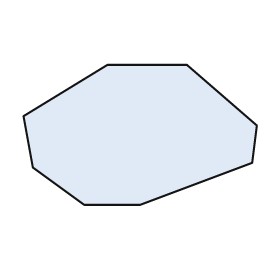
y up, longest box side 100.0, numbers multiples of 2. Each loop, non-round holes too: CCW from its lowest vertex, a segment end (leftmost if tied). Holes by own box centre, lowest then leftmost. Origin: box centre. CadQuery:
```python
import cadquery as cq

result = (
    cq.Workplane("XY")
    .moveTo(-24.0, -30.0)
    .lineTo(0.0, -30.0)
    .lineTo(48.0, -12.0)
    .lineTo(50.0, 4.0)
    .lineTo(20.0, 30.0)
    .lineTo(-14.0, 30.0)
    .lineTo(-50.0, 8.0)
    .lineTo(-46.0, -14.0)
    .close()
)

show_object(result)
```